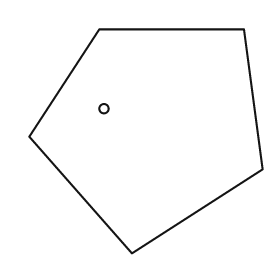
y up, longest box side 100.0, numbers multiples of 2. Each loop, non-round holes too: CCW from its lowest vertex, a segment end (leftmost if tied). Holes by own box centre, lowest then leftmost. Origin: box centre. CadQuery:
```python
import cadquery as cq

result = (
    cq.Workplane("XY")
    .moveTo(-6.0, -48.0)
    .lineTo(50.0, -12.0)
    .lineTo(42.0, 48.0)
    .lineTo(-20.0, 48.0)
    .lineTo(-50.0, 2.0)
    .close()
    .moveTo(-18.0, 14.0)
    .circle(2.0)
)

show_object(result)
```